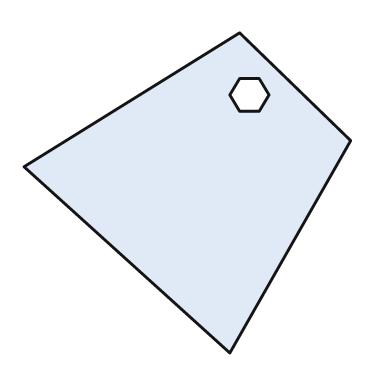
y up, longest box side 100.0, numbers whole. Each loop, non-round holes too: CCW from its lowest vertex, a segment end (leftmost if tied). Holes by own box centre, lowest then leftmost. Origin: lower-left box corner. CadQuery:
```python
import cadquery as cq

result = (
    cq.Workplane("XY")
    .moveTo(63.0, 0.0)
    .lineTo(100.0, 65.0)
    .lineTo(66.0, 98.0)
    .lineTo(0.0, 57.0)
    .close()
    .moveTo(66.0, 74.0)
    .lineTo(72.0, 74.0)
    .lineTo(75.0, 79.0)
    .lineTo(72.0, 84.0)
    .lineTo(66.0, 84.0)
    .lineTo(63.0, 79.0)
    .close()
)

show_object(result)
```